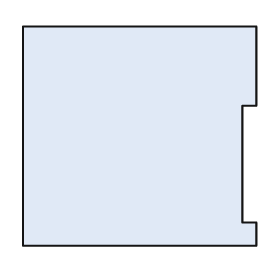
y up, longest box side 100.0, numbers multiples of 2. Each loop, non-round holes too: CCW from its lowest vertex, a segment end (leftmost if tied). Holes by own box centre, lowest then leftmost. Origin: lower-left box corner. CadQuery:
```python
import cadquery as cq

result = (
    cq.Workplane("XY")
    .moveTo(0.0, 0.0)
    .lineTo(100.0, 0.0)
    .lineTo(100.0, 10.0)
    .lineTo(94.0, 10.0)
    .lineTo(94.0, 60.0)
    .lineTo(100.0, 60.0)
    .lineTo(100.0, 94.0)
    .lineTo(0.0, 94.0)
    .close()
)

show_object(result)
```